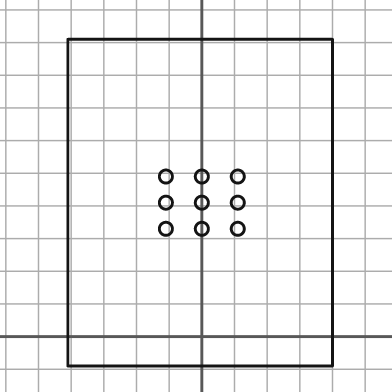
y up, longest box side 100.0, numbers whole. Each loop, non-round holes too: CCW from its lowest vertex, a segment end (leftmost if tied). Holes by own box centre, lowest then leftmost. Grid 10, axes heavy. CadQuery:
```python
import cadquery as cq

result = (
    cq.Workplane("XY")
    .moveTo(-41.0, -9.0)
    .lineTo(40.0, -9.0)
    .lineTo(40.0, 91.0)
    .lineTo(-41.0, 91.0)
    .close()
    .moveTo(-11.0, 33.0)
    .circle(2.0)
    .moveTo(0.0, 33.0)
    .circle(2.0)
    .moveTo(11.0, 33.0)
    .circle(2.0)
    .moveTo(-11.0, 41.0)
    .circle(2.0)
    .moveTo(0.0, 41.0)
    .circle(2.0)
    .moveTo(11.0, 41.0)
    .circle(2.0)
    .moveTo(-11.0, 49.0)
    .circle(2.0)
    .moveTo(0.0, 49.0)
    .circle(2.0)
    .moveTo(11.0, 49.0)
    .circle(2.0)
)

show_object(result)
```